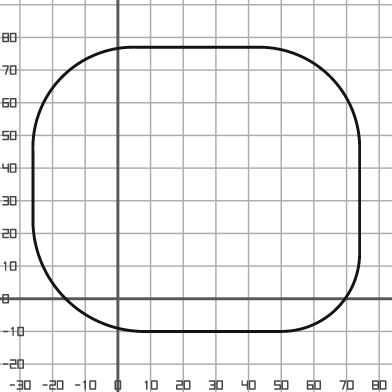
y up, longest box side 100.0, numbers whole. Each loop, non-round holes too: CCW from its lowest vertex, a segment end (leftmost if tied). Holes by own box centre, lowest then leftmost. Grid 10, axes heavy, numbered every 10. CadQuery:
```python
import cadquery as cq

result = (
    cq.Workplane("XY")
    .moveTo(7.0, -10.0)
    .lineTo(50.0, -10.0)
    .threePointArc((67.0, -3.0), (74.0, 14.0))
    .lineTo(74.0, 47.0)
    .threePointArc((65.0, 68.0), (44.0, 77.0))
    .lineTo(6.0, 77.0)
    .threePointArc((-17.0, 68.0), (-26.0, 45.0))
    .lineTo(-26.0, 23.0)
    .threePointArc((-16.0, 0.0), (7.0, -10.0))
    .close()
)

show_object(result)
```